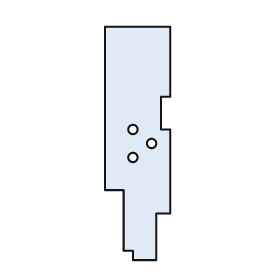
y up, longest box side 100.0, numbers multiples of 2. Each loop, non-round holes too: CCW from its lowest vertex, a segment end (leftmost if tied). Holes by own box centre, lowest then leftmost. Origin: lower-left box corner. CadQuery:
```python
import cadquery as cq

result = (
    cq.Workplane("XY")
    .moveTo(12.0, 0.0)
    .lineTo(22.0, 0.0)
    .lineTo(22.0, 20.0)
    .lineTo(28.0, 20.0)
    .lineTo(28.0, 56.0)
    .lineTo(24.0, 56.0)
    .lineTo(24.0, 70.0)
    .lineTo(28.0, 70.0)
    .lineTo(28.0, 100.0)
    .lineTo(0.0, 100.0)
    .lineTo(0.0, 30.0)
    .lineTo(8.0, 30.0)
    .lineTo(8.0, 4.0)
    .lineTo(12.0, 4.0)
    .close()
    .moveTo(12.0, 44.0)
    .circle(2.0)
    .moveTo(20.0, 50.0)
    .circle(2.0)
    .moveTo(12.0, 56.0)
    .circle(2.0)
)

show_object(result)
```